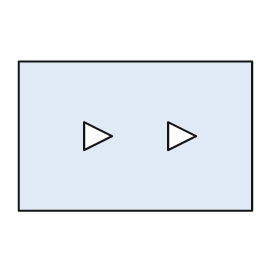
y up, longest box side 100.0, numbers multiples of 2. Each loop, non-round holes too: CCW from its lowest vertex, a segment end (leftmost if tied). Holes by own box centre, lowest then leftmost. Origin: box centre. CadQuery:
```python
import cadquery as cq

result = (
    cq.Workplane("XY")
    .moveTo(-50.0, -32.0)
    .lineTo(50.0, -32.0)
    .lineTo(50.0, 32.0)
    .lineTo(-50.0, 32.0)
    .close()
    .moveTo(-22.0, -6.0)
    .lineTo(-10.0, 0.0)
    .lineTo(-22.0, 6.0)
    .close()
    .moveTo(14.0, -6.0)
    .lineTo(26.0, 0.0)
    .lineTo(14.0, 6.0)
    .close()
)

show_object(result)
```